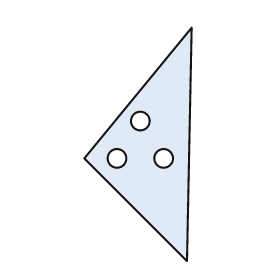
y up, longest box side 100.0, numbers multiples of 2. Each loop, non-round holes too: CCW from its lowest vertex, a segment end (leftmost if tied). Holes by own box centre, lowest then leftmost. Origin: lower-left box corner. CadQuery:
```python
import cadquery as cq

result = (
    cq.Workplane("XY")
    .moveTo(44.0, 0.0)
    .lineTo(46.0, 100.0)
    .lineTo(0.0, 44.0)
    .close()
    .moveTo(14.0, 44.0)
    .circle(4.0)
    .moveTo(34.0, 44.0)
    .circle(4.0)
    .moveTo(24.0, 60.0)
    .circle(4.0)
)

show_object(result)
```